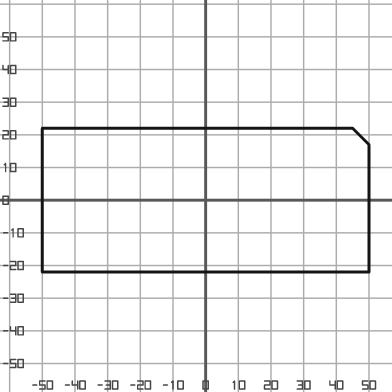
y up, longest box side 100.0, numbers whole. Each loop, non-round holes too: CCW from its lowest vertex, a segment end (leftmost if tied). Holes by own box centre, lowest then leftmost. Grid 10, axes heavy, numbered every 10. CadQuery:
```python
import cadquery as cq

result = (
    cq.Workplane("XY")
    .moveTo(-50.0, -22.0)
    .lineTo(50.0, -22.0)
    .lineTo(50.0, 17.0)
    .lineTo(45.0, 22.0)
    .lineTo(-50.0, 22.0)
    .close()
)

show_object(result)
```